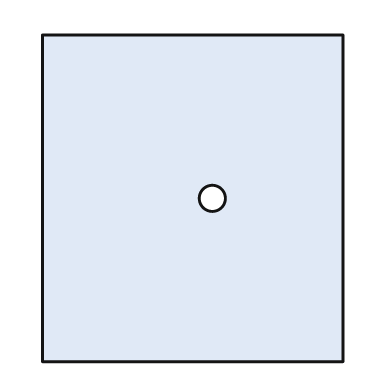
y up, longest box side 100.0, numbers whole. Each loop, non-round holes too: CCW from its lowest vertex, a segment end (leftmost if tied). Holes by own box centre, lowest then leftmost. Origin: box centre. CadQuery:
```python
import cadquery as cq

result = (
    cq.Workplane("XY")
    .moveTo(-46.0, -50.0)
    .lineTo(46.0, -50.0)
    .lineTo(46.0, 50.0)
    .lineTo(-46.0, 50.0)
    .close()
    .moveTo(6.0, 0.0)
    .circle(4.0)
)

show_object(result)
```